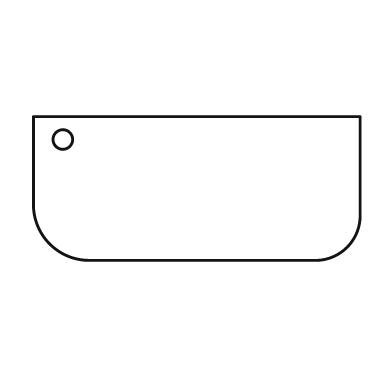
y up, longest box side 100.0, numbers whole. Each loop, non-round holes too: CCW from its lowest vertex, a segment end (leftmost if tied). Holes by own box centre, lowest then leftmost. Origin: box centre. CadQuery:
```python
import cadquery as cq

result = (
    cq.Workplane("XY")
    .moveTo(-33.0, -22.0)
    .lineTo(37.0, -22.0)
    .threePointArc((46.0, -18.0), (50.0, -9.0))
    .lineTo(50.0, 22.0)
    .lineTo(-50.0, 22.0)
    .lineTo(-50.0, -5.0)
    .threePointArc((-45.0, -17.0), (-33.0, -22.0))
    .close()
    .moveTo(-41.0, 15.0)
    .circle(3.0)
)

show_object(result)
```